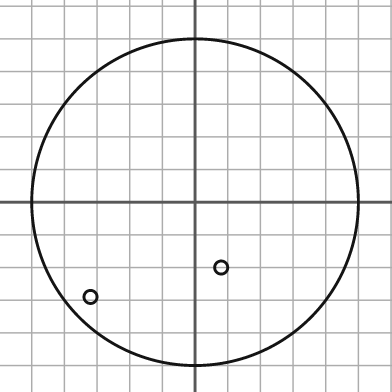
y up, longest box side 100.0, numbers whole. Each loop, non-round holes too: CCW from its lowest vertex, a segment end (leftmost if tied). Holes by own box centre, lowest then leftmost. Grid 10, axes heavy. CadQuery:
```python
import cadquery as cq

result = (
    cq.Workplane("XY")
    .moveTo(0.0, 0.0)
    .circle(50.0)
    .moveTo(-32.0, -29.0)
    .circle(2.0)
    .moveTo(8.0, -20.0)
    .circle(2.0)
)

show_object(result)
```